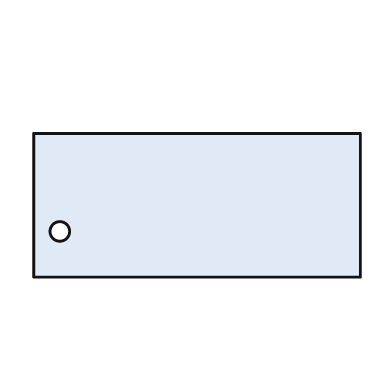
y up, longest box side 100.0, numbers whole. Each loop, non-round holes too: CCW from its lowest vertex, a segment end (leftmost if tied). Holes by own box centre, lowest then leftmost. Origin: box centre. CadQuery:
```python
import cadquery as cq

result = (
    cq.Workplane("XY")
    .moveTo(-50.0, -22.0)
    .lineTo(50.0, -22.0)
    .lineTo(50.0, 22.0)
    .lineTo(-50.0, 22.0)
    .close()
    .moveTo(-42.0, -8.0)
    .circle(3.0)
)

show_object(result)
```